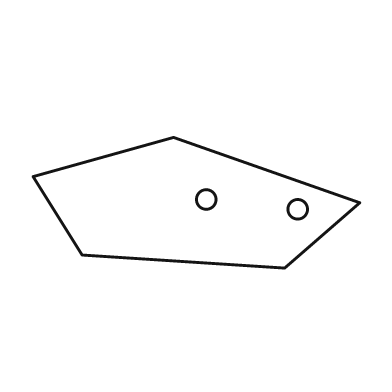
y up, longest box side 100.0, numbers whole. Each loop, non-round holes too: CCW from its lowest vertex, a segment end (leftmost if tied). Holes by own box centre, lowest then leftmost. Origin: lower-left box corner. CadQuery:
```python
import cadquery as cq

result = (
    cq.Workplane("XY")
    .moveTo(77.0, 0.0)
    .lineTo(100.0, 20.0)
    .lineTo(43.0, 40.0)
    .lineTo(0.0, 28.0)
    .lineTo(15.0, 4.0)
    .close()
    .moveTo(81.0, 18.0)
    .circle(3.0)
    .moveTo(53.0, 21.0)
    .circle(3.0)
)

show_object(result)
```